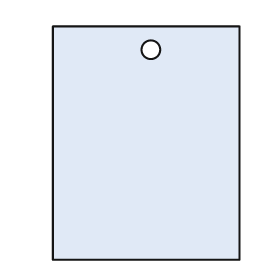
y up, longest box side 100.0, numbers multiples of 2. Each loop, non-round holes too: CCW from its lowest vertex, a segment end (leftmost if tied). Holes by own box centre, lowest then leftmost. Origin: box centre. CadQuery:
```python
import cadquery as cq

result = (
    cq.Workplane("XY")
    .moveTo(-40.0, -50.0)
    .lineTo(40.0, -50.0)
    .lineTo(40.0, 50.0)
    .lineTo(-40.0, 50.0)
    .close()
    .moveTo(2.0, 40.0)
    .circle(4.0)
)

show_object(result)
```